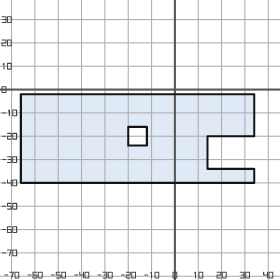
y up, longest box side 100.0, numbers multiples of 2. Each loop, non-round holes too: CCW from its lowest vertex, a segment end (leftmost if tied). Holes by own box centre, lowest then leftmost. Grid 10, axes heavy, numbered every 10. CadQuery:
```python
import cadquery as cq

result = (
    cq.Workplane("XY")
    .moveTo(-66.0, -40.0)
    .lineTo(34.0, -40.0)
    .lineTo(34.0, -34.0)
    .lineTo(14.0, -34.0)
    .lineTo(14.0, -20.0)
    .lineTo(34.0, -20.0)
    .lineTo(34.0, -2.0)
    .lineTo(-66.0, -2.0)
    .close()
    .moveTo(-20.0, -24.0)
    .lineTo(-12.0, -24.0)
    .lineTo(-12.0, -16.0)
    .lineTo(-20.0, -16.0)
    .close()
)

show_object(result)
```